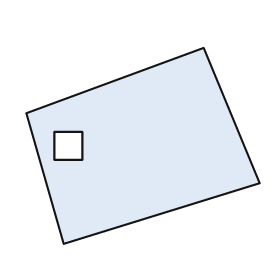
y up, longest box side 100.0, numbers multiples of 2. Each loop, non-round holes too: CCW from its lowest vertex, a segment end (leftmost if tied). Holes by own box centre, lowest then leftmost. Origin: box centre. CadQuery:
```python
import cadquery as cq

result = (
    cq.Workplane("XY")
    .moveTo(-34.0, -42.0)
    .lineTo(50.0, -16.0)
    .lineTo(26.0, 42.0)
    .lineTo(-50.0, 14.0)
    .close()
    .moveTo(-38.0, -6.0)
    .lineTo(-26.0, -6.0)
    .lineTo(-26.0, 6.0)
    .lineTo(-38.0, 6.0)
    .close()
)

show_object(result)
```